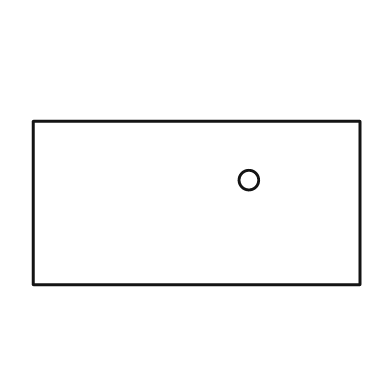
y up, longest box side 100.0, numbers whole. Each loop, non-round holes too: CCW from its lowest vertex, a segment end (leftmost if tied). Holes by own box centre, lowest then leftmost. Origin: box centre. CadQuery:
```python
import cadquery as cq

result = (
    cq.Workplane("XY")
    .moveTo(-50.0, -25.0)
    .lineTo(50.0, -25.0)
    .lineTo(50.0, 25.0)
    .lineTo(-50.0, 25.0)
    .close()
    .moveTo(16.0, 7.0)
    .circle(3.0)
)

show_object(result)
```